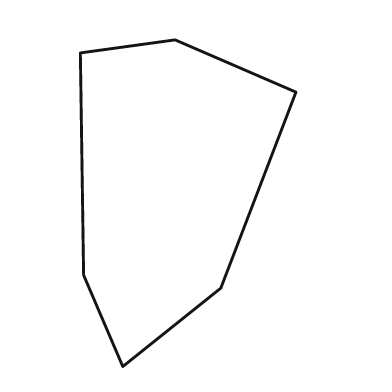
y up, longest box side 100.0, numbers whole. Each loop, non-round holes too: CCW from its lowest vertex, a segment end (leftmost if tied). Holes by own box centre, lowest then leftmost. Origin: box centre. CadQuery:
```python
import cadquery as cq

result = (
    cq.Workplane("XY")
    .moveTo(-20.0, -50.0)
    .lineTo(10.0, -26.0)
    .lineTo(33.0, 34.0)
    .lineTo(-4.0, 50.0)
    .lineTo(-33.0, 46.0)
    .lineTo(-32.0, -22.0)
    .close()
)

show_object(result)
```